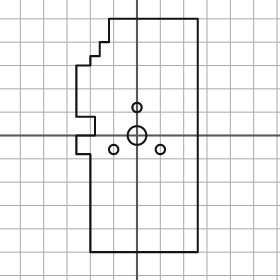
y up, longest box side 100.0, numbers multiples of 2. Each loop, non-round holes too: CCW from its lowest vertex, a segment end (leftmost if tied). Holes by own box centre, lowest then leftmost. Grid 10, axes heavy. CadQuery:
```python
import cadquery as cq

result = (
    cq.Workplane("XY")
    .moveTo(-20.0, -50.0)
    .lineTo(26.0, -50.0)
    .lineTo(26.0, 50.0)
    .lineTo(-12.0, 50.0)
    .lineTo(-12.0, 40.0)
    .lineTo(-16.0, 40.0)
    .lineTo(-16.0, 34.0)
    .lineTo(-20.0, 34.0)
    .lineTo(-20.0, 30.0)
    .lineTo(-26.0, 30.0)
    .lineTo(-26.0, 8.0)
    .lineTo(-18.0, 8.0)
    .lineTo(-18.0, 0.0)
    .lineTo(-26.0, 0.0)
    .lineTo(-26.0, -8.0)
    .lineTo(-20.0, -8.0)
    .close()
    .moveTo(-10.0, -6.0)
    .circle(2.0)
    .moveTo(10.0, -6.0)
    .circle(2.0)
    .moveTo(0.0, 0.0)
    .circle(4.0)
    .moveTo(0.0, 12.0)
    .circle(2.0)
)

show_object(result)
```